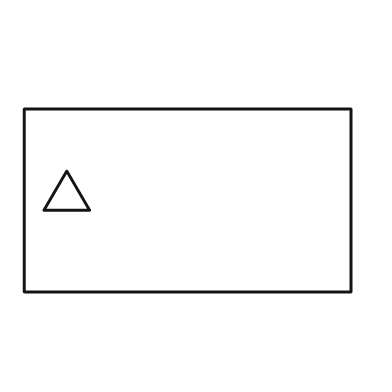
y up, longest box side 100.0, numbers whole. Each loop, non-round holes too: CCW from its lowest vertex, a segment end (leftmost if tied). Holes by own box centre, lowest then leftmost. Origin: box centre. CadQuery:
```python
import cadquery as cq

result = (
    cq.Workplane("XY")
    .moveTo(-50.0, -28.0)
    .lineTo(50.0, -28.0)
    .lineTo(50.0, 28.0)
    .lineTo(-50.0, 28.0)
    .close()
    .moveTo(-44.0, -3.0)
    .lineTo(-30.0, -3.0)
    .lineTo(-37.0, 9.0)
    .close()
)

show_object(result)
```